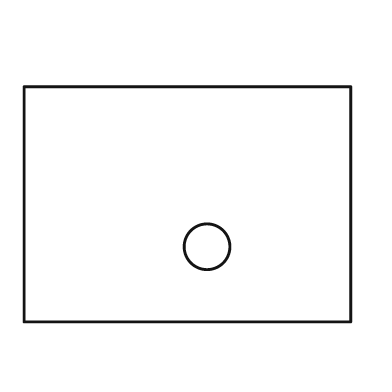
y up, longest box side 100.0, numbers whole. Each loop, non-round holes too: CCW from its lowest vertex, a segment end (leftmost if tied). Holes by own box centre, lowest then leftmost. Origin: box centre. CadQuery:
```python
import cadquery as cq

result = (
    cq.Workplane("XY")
    .moveTo(-50.0, -36.0)
    .lineTo(50.0, -36.0)
    .lineTo(50.0, 36.0)
    .lineTo(-50.0, 36.0)
    .close()
    .moveTo(6.0, -13.0)
    .circle(7.0)
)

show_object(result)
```